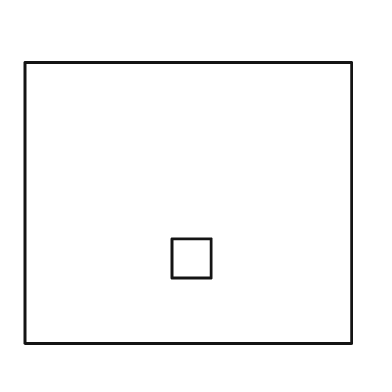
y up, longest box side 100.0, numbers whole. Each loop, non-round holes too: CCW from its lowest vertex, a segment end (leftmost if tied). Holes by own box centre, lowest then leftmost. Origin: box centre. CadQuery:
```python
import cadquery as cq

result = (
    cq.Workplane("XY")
    .moveTo(-50.0, -43.0)
    .lineTo(50.0, -43.0)
    .lineTo(50.0, 43.0)
    .lineTo(-50.0, 43.0)
    .close()
    .moveTo(-5.0, -23.0)
    .lineTo(7.0, -23.0)
    .lineTo(7.0, -11.0)
    .lineTo(-5.0, -11.0)
    .close()
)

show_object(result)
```